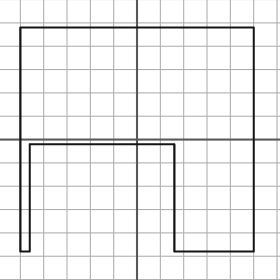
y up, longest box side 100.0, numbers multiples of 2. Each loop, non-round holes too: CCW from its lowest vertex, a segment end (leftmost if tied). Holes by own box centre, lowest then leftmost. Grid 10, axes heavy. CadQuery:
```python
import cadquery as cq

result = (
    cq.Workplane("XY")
    .moveTo(-50.0, -48.0)
    .lineTo(-46.0, -48.0)
    .lineTo(-46.0, -2.0)
    .lineTo(16.0, -2.0)
    .lineTo(16.0, -48.0)
    .lineTo(50.0, -48.0)
    .lineTo(50.0, 48.0)
    .lineTo(-50.0, 48.0)
    .close()
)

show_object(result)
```